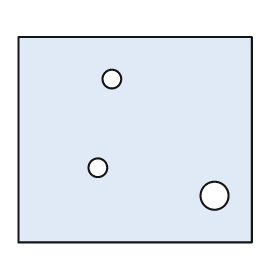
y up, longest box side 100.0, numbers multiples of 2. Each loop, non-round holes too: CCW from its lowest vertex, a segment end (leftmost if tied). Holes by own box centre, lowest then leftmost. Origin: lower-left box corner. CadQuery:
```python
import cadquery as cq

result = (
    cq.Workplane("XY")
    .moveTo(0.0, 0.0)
    .lineTo(100.0, 0.0)
    .lineTo(100.0, 88.0)
    .lineTo(0.0, 88.0)
    .close()
    .moveTo(84.0, 20.0)
    .circle(6.0)
    .moveTo(34.0, 32.0)
    .circle(4.0)
    .moveTo(40.0, 70.0)
    .circle(4.0)
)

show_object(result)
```